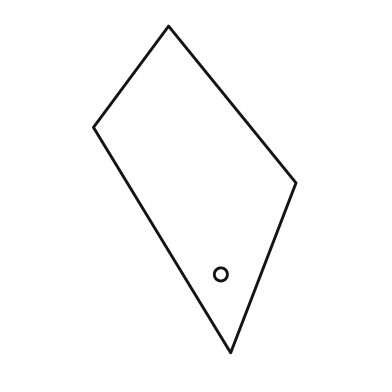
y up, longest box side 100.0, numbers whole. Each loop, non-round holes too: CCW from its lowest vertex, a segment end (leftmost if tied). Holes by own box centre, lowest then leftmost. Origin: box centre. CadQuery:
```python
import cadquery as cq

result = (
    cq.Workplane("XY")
    .moveTo(11.0, -50.0)
    .lineTo(31.0, 2.0)
    .lineTo(-8.0, 50.0)
    .lineTo(-31.0, 19.0)
    .close()
    .moveTo(8.0, -26.0)
    .circle(2.0)
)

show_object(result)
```